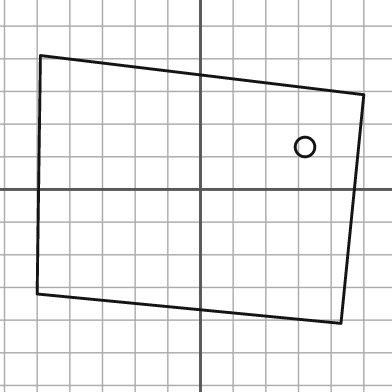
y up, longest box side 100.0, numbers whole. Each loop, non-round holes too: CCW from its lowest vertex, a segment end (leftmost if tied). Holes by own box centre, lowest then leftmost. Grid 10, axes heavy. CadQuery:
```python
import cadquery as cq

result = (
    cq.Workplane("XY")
    .moveTo(43.0, -41.0)
    .lineTo(50.0, 29.0)
    .lineTo(-49.0, 41.0)
    .lineTo(-50.0, -32.0)
    .close()
    .moveTo(32.0, 13.0)
    .circle(3.0)
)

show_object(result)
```